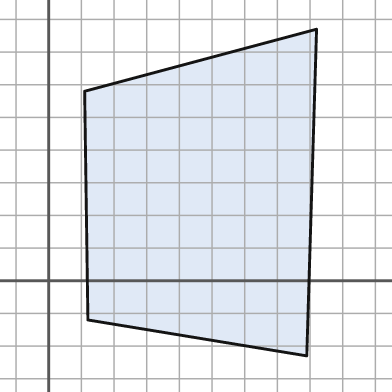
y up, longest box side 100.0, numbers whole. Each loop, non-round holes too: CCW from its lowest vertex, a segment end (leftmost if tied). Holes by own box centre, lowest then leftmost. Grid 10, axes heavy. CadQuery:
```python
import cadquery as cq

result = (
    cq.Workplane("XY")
    .moveTo(79.0, -23.0)
    .lineTo(82.0, 77.0)
    .lineTo(11.0, 58.0)
    .lineTo(12.0, -12.0)
    .close()
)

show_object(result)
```